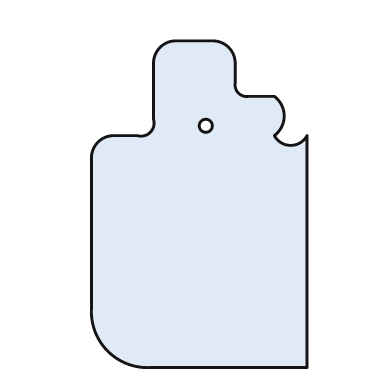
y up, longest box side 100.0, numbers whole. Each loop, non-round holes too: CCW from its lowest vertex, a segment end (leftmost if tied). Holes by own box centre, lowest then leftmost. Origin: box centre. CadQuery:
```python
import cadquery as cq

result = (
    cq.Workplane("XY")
    .moveTo(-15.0, -50.0)
    .lineTo(33.0, -50.0)
    .lineTo(33.0, 21.0)
    .threePointArc((28.0, 18.0), (23.0, 21.0))
    .threePointArc((26.0, 27.0), (23.0, 33.0))
    .lineTo(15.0, 33.0)
    .threePointArc((12.0, 34.0), (11.0, 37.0))
    .lineTo(11.0, 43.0)
    .threePointArc((9.0, 48.0), (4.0, 50.0))
    .lineTo(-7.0, 50.0)
    .threePointArc((-12.0, 48.0), (-14.0, 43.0))
    .lineTo(-14.0, 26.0)
    .threePointArc((-15.0, 22.0), (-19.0, 21.0))
    .lineTo(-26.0, 21.0)
    .threePointArc((-31.0, 19.0), (-33.0, 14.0))
    .lineTo(-33.0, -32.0)
    .threePointArc((-28.0, -45.0), (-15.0, -50.0))
    .close()
    .moveTo(2.0, 24.0)
    .circle(2.0)
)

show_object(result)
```